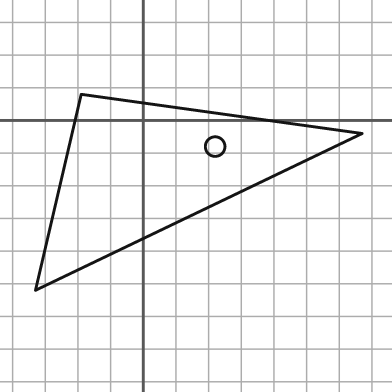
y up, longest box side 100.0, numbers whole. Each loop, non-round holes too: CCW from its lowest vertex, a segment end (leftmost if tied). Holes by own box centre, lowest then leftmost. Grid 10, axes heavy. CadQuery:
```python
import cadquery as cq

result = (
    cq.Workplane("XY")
    .moveTo(-33.0, -52.0)
    .lineTo(67.0, -4.0)
    .lineTo(-19.0, 8.0)
    .close()
    .moveTo(22.0, -8.0)
    .circle(3.0)
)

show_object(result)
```